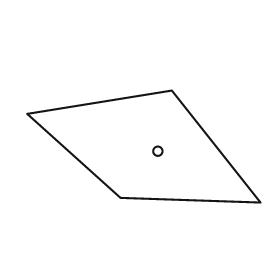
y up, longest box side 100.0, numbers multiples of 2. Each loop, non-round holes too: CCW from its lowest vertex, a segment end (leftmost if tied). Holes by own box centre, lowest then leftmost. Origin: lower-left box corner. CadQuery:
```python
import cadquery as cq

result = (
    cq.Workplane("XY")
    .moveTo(100.0, 0.0)
    .lineTo(62.0, 48.0)
    .lineTo(0.0, 38.0)
    .lineTo(40.0, 2.0)
    .close()
    .moveTo(56.0, 22.0)
    .circle(2.0)
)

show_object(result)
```